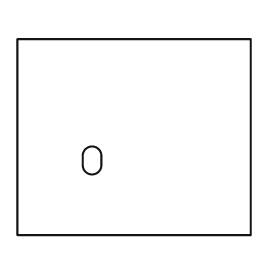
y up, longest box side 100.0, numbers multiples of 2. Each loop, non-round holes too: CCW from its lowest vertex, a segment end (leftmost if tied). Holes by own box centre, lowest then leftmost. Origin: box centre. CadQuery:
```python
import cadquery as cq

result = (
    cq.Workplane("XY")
    .moveTo(-50.0, -42.0)
    .lineTo(50.0, -42.0)
    .lineTo(50.0, 42.0)
    .lineTo(-50.0, 42.0)
    .close()
    .moveTo(-22.0, -12.0)
    .threePointArc((-18.0, -16.0), (-14.0, -12.0))
    .lineTo(-14.0, -8.0)
    .threePointArc((-18.0, -4.0), (-22.0, -8.0))
    .close()
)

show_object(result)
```